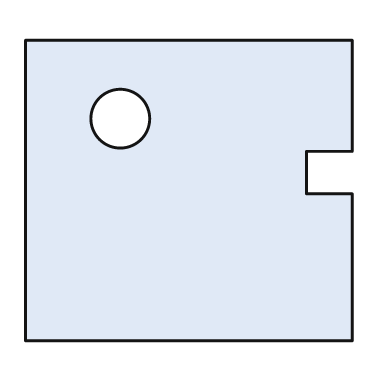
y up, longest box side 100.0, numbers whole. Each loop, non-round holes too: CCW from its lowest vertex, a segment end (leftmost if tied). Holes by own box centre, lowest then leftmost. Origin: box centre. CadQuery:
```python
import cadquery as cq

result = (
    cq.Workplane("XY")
    .moveTo(-50.0, -46.0)
    .lineTo(50.0, -46.0)
    .lineTo(50.0, -1.0)
    .lineTo(36.0, -1.0)
    .lineTo(36.0, 12.0)
    .lineTo(50.0, 12.0)
    .lineTo(50.0, 46.0)
    .lineTo(-50.0, 46.0)
    .close()
    .moveTo(-21.0, 22.0)
    .circle(9.0)
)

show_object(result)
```